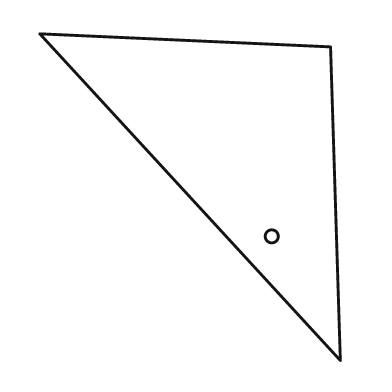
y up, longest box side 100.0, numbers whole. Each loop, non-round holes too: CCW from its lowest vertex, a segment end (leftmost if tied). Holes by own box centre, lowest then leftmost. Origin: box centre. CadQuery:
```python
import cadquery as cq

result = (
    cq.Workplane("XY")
    .moveTo(46.0, -50.0)
    .lineTo(43.0, 46.0)
    .lineTo(-46.0, 50.0)
    .close()
    .moveTo(25.0, -12.0)
    .circle(2.0)
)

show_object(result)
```